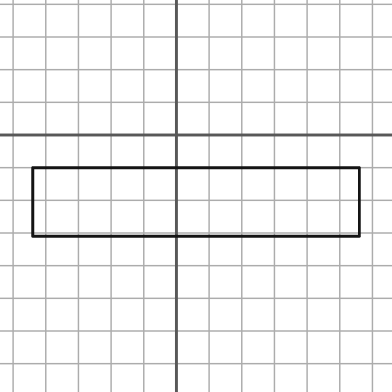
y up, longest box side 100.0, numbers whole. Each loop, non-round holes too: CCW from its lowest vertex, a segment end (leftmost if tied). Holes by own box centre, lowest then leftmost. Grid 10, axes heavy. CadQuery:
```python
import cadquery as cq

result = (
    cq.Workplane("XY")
    .moveTo(-44.0, -31.0)
    .lineTo(56.0, -31.0)
    .lineTo(56.0, -10.0)
    .lineTo(-44.0, -10.0)
    .close()
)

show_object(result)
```